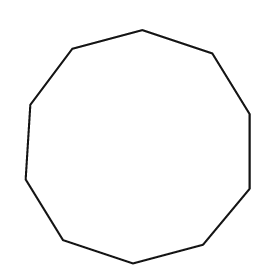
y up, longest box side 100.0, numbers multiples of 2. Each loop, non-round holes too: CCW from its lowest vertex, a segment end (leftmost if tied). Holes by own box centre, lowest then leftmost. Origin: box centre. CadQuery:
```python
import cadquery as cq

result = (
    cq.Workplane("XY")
    .moveTo(-2.0, -50.0)
    .lineTo(28.0, -42.0)
    .lineTo(48.0, -18.0)
    .lineTo(48.0, 14.0)
    .lineTo(32.0, 40.0)
    .lineTo(2.0, 50.0)
    .lineTo(-28.0, 42.0)
    .lineTo(-46.0, 18.0)
    .lineTo(-48.0, -14.0)
    .lineTo(-32.0, -40.0)
    .close()
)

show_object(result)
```